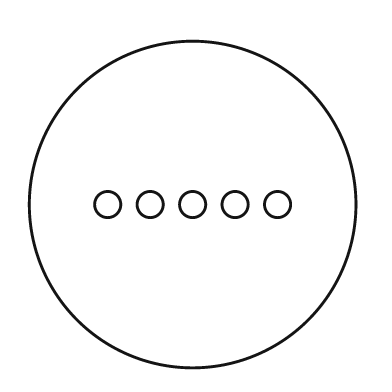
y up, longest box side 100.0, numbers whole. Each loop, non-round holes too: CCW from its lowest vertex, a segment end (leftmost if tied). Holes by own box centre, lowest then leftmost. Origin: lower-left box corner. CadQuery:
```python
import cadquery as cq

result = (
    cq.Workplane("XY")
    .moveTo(50.0, 50.0)
    .circle(50.0)
    .moveTo(24.0, 50.0)
    .circle(4.0)
    .moveTo(37.0, 50.0)
    .circle(4.0)
    .moveTo(50.0, 50.0)
    .circle(4.0)
    .moveTo(63.0, 50.0)
    .circle(4.0)
    .moveTo(76.0, 50.0)
    .circle(4.0)
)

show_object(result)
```